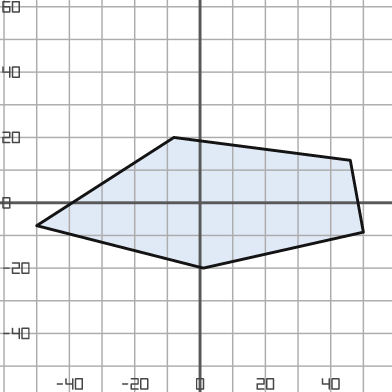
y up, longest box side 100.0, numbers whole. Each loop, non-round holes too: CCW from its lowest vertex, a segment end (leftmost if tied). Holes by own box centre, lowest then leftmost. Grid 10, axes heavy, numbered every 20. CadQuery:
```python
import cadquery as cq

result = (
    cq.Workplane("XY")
    .moveTo(1.0, -20.0)
    .lineTo(50.0, -9.0)
    .lineTo(46.0, 13.0)
    .lineTo(-8.0, 20.0)
    .lineTo(-50.0, -7.0)
    .close()
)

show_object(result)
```